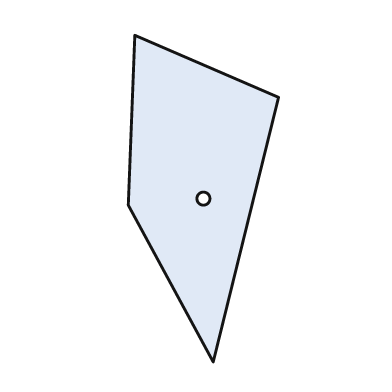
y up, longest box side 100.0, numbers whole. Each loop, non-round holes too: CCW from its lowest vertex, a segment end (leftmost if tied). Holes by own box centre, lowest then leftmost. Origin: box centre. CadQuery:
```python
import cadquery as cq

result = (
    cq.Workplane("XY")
    .moveTo(3.0, -50.0)
    .lineTo(23.0, 31.0)
    .lineTo(-21.0, 50.0)
    .lineTo(-23.0, -2.0)
    .close()
    .moveTo(0.0, 0.0)
    .circle(2.0)
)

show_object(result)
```